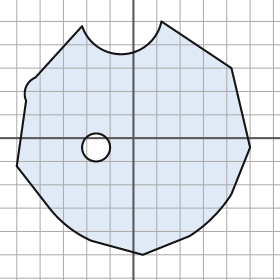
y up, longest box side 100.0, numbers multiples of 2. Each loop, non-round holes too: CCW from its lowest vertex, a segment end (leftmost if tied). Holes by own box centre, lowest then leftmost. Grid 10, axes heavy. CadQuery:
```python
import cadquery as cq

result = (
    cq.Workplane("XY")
    .moveTo(4.0, -50.0)
    .lineTo(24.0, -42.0)
    .threePointArc((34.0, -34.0), (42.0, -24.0))
    .lineTo(50.0, -4.0)
    .lineTo(42.0, 30.0)
    .lineTo(12.0, 50.0)
    .threePointArc((-4.0, 36.0), (-22.0, 48.0))
    .lineTo(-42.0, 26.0)
    .threePointArc((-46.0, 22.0), (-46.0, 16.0))
    .lineTo(-50.0, -12.0)
    .lineTo(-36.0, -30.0)
    .threePointArc((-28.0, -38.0), (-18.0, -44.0))
    .close()
    .moveTo(-16.0, -4.0)
    .circle(6.0)
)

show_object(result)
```